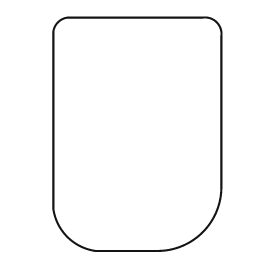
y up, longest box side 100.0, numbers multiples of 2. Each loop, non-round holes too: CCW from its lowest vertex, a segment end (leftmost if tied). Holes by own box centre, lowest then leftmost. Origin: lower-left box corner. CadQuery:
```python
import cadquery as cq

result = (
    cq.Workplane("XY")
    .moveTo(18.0, 0.0)
    .lineTo(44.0, 0.0)
    .threePointArc((64.0, 8.0), (72.0, 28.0))
    .lineTo(72.0, 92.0)
    .threePointArc((70.0, 98.0), (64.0, 100.0))
    .lineTo(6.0, 100.0)
    .threePointArc((2.0, 98.0), (0.0, 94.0))
    .lineTo(0.0, 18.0)
    .threePointArc((6.0, 6.0), (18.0, 0.0))
    .close()
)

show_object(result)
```